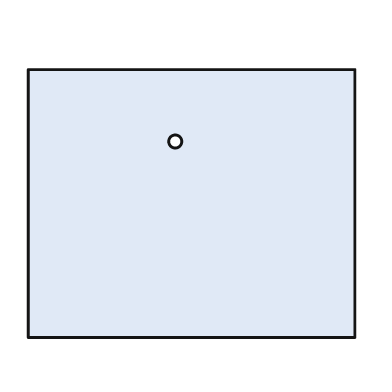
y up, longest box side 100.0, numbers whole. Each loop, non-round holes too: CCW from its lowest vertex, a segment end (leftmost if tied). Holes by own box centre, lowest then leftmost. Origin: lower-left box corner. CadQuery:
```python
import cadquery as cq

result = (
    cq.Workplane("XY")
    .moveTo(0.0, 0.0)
    .lineTo(100.0, 0.0)
    .lineTo(100.0, 82.0)
    .lineTo(0.0, 82.0)
    .close()
    .moveTo(45.0, 60.0)
    .circle(2.0)
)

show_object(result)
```